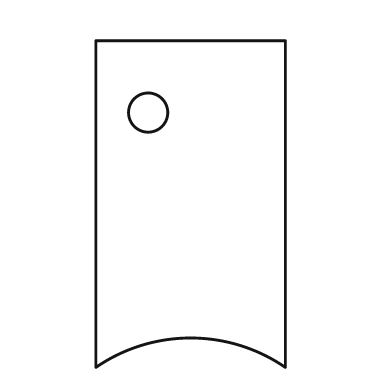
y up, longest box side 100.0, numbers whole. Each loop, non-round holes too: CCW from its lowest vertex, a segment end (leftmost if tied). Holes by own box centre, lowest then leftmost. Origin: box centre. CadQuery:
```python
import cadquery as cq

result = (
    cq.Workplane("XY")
    .moveTo(-29.0, -50.0)
    .threePointArc((0.0, -41.0), (29.0, -50.0))
    .lineTo(29.0, 50.0)
    .lineTo(-29.0, 50.0)
    .close()
    .moveTo(-13.0, 28.0)
    .circle(6.0)
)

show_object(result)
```